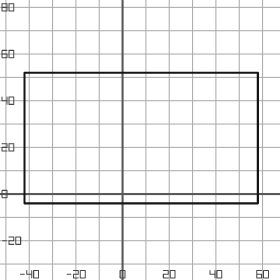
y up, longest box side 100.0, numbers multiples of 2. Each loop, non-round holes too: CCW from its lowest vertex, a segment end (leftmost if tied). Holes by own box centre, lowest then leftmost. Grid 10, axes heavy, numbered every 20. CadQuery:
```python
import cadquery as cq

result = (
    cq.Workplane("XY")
    .moveTo(-42.0, -4.0)
    .lineTo(58.0, -4.0)
    .lineTo(58.0, 52.0)
    .lineTo(-42.0, 52.0)
    .close()
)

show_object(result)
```